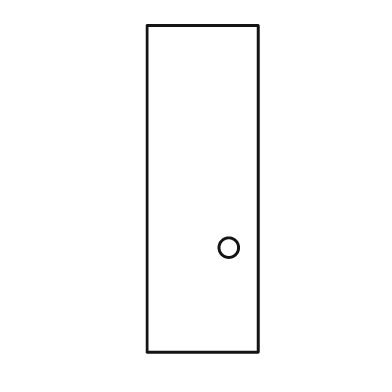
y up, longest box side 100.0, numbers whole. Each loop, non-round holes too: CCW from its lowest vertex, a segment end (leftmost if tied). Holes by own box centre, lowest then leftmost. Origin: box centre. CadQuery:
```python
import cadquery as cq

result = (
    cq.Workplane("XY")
    .moveTo(-17.0, -50.0)
    .lineTo(17.0, -50.0)
    .lineTo(17.0, 50.0)
    .lineTo(-17.0, 50.0)
    .close()
    .moveTo(8.0, -18.0)
    .circle(3.0)
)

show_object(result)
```